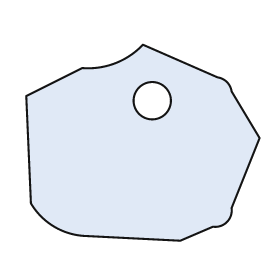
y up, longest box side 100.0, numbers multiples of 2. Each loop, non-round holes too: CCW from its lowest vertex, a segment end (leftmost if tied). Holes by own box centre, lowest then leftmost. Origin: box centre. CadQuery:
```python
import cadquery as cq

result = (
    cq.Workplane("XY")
    .moveTo(16.0, -42.0)
    .lineTo(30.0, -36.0)
    .threePointArc((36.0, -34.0), (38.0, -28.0))
    .lineTo(50.0, 2.0)
    .lineTo(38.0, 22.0)
    .threePointArc((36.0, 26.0), (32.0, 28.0))
    .lineTo(0.0, 42.0)
    .threePointArc((-12.0, 34.0), (-26.0, 32.0))
    .lineTo(-50.0, 20.0)
    .lineTo(-48.0, -26.0)
    .threePointArc((-38.0, -36.0), (-24.0, -40.0))
    .close()
    .moveTo(4.0, 18.0)
    .circle(8.0)
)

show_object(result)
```